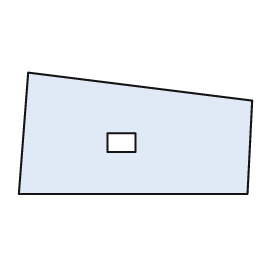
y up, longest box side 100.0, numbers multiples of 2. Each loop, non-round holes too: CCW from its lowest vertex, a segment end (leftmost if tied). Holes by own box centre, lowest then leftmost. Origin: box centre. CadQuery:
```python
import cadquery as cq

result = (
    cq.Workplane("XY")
    .moveTo(-50.0, -26.0)
    .lineTo(48.0, -26.0)
    .lineTo(50.0, 14.0)
    .lineTo(-46.0, 26.0)
    .close()
    .moveTo(-12.0, -8.0)
    .lineTo(0.0, -8.0)
    .lineTo(0.0, 0.0)
    .lineTo(-12.0, 0.0)
    .close()
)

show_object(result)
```